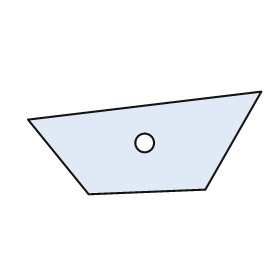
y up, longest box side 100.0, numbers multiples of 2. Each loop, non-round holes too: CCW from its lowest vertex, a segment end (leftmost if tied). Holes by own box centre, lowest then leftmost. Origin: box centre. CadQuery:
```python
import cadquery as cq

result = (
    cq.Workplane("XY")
    .moveTo(-24.0, -22.0)
    .lineTo(26.0, -20.0)
    .lineTo(50.0, 22.0)
    .lineTo(-50.0, 10.0)
    .close()
    .moveTo(0.0, 0.0)
    .circle(4.0)
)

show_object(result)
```